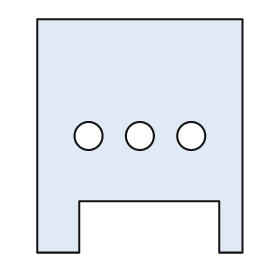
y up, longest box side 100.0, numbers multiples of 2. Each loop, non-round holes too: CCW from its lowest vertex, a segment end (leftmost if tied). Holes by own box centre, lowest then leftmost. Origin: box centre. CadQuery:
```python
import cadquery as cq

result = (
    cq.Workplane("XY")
    .moveTo(-44.0, -50.0)
    .lineTo(-26.0, -50.0)
    .lineTo(-26.0, -28.0)
    .lineTo(34.0, -28.0)
    .lineTo(34.0, -50.0)
    .lineTo(44.0, -50.0)
    .lineTo(44.0, 50.0)
    .lineTo(-44.0, 50.0)
    .close()
    .moveTo(-22.0, 0.0)
    .circle(6.0)
    .moveTo(0.0, 0.0)
    .circle(6.0)
    .moveTo(22.0, 0.0)
    .circle(6.0)
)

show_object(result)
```